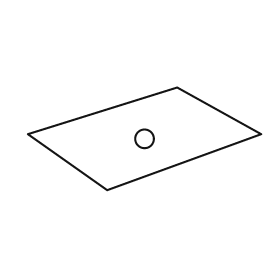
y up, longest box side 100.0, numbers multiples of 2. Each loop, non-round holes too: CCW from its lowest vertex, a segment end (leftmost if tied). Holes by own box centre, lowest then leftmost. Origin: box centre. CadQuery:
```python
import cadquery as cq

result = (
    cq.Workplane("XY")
    .moveTo(-16.0, -22.0)
    .lineTo(50.0, 2.0)
    .lineTo(14.0, 22.0)
    .lineTo(-50.0, 2.0)
    .close()
    .moveTo(0.0, 0.0)
    .circle(4.0)
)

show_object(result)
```